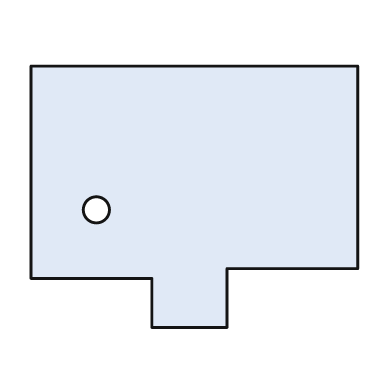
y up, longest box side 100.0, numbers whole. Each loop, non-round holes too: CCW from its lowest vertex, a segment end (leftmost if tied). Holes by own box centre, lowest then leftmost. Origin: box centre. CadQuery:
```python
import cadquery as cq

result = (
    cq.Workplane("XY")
    .moveTo(-13.0, -40.0)
    .lineTo(10.0, -40.0)
    .lineTo(10.0, -22.0)
    .lineTo(50.0, -22.0)
    .lineTo(50.0, 40.0)
    .lineTo(-50.0, 40.0)
    .lineTo(-50.0, -25.0)
    .lineTo(-13.0, -25.0)
    .close()
    .moveTo(-30.0, -4.0)
    .circle(4.0)
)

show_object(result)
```